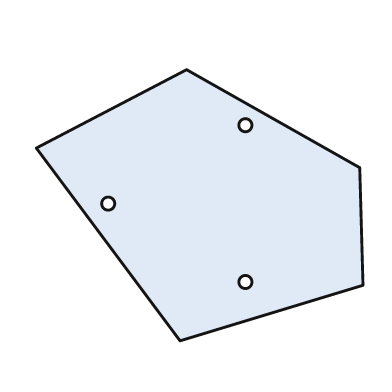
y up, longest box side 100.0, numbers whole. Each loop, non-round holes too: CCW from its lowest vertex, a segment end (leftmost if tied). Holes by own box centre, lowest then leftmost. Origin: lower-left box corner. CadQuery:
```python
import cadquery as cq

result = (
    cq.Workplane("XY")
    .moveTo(44.0, 0.0)
    .lineTo(100.0, 17.0)
    .lineTo(99.0, 53.0)
    .lineTo(46.0, 83.0)
    .lineTo(0.0, 59.0)
    .close()
    .moveTo(64.0, 18.0)
    .circle(2.0)
    .moveTo(22.0, 42.0)
    .circle(2.0)
    .moveTo(64.0, 66.0)
    .circle(2.0)
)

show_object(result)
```